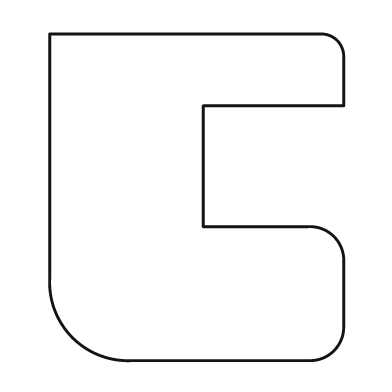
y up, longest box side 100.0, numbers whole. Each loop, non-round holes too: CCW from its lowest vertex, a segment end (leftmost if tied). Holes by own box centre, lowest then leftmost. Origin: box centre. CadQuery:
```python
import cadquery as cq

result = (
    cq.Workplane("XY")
    .moveTo(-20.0, -50.0)
    .lineTo(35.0, -50.0)
    .threePointArc((42.0, -47.0), (45.0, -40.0))
    .lineTo(45.0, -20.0)
    .threePointArc((42.0, -12.0), (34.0, -9.0))
    .lineTo(2.0, -9.0)
    .lineTo(2.0, 28.0)
    .lineTo(45.0, 28.0)
    .lineTo(45.0, 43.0)
    .threePointArc((43.0, 48.0), (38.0, 50.0))
    .lineTo(-45.0, 50.0)
    .lineTo(-45.0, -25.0)
    .threePointArc((-38.0, -43.0), (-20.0, -50.0))
    .close()
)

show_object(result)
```